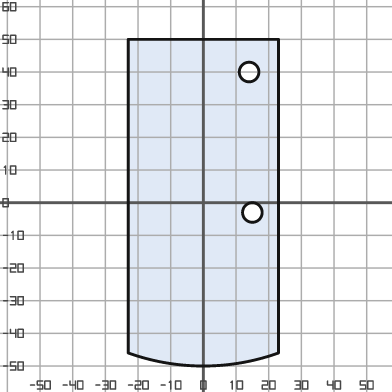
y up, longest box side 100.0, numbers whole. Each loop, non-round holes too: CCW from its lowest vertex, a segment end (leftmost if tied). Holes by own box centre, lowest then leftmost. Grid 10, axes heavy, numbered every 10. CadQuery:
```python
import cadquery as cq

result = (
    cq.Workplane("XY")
    .moveTo(-23.0, -46.0)
    .threePointArc((0.0, -50.0), (23.0, -46.0))
    .lineTo(23.0, 50.0)
    .lineTo(-23.0, 50.0)
    .close()
    .moveTo(15.0, -3.0)
    .circle(3.0)
    .moveTo(14.0, 40.0)
    .circle(3.0)
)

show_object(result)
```